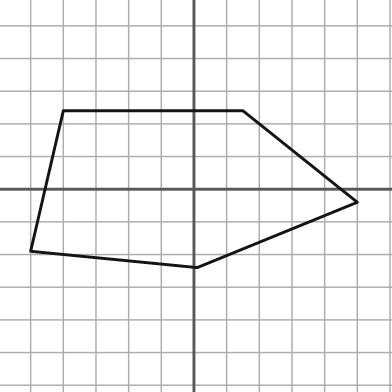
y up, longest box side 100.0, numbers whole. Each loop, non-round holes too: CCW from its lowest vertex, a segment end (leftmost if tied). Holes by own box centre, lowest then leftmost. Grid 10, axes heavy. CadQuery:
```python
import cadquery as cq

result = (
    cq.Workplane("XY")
    .moveTo(1.0, -24.0)
    .lineTo(50.0, -4.0)
    .lineTo(15.0, 24.0)
    .lineTo(-40.0, 24.0)
    .lineTo(-50.0, -19.0)
    .close()
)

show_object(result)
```